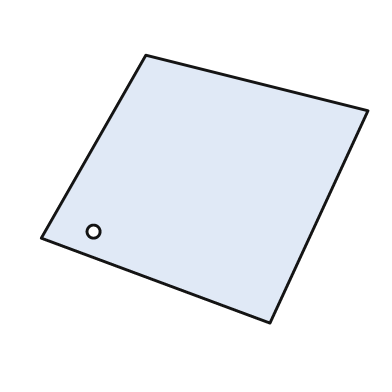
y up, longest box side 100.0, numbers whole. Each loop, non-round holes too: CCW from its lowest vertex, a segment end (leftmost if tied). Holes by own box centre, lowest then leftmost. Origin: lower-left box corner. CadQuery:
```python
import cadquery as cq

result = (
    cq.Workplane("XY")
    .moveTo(70.0, 0.0)
    .lineTo(100.0, 65.0)
    .lineTo(32.0, 82.0)
    .lineTo(0.0, 26.0)
    .close()
    .moveTo(16.0, 28.0)
    .circle(2.0)
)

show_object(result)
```